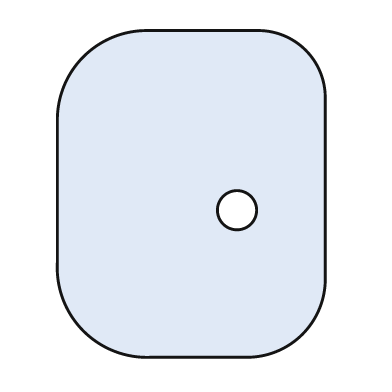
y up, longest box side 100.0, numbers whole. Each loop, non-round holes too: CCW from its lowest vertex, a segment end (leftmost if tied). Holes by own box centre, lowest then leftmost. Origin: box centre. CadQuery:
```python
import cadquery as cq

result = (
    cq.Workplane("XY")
    .moveTo(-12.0, -50.0)
    .lineTo(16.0, -50.0)
    .threePointArc((34.0, -43.0), (41.0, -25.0))
    .lineTo(41.0, 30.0)
    .threePointArc((35.0, 44.0), (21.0, 50.0))
    .lineTo(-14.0, 50.0)
    .threePointArc((-33.0, 42.0), (-41.0, 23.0))
    .lineTo(-41.0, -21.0)
    .threePointArc((-33.0, -42.0), (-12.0, -50.0))
    .close()
    .moveTo(14.0, -5.0)
    .circle(6.0)
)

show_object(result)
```